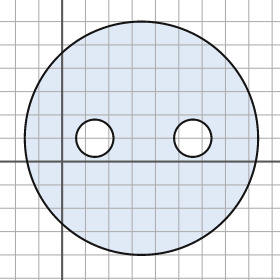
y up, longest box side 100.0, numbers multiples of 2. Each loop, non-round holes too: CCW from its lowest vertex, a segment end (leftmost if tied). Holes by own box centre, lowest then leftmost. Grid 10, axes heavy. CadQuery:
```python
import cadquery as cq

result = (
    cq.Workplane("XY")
    .moveTo(34.0, 10.0)
    .circle(50.0)
    .moveTo(14.0, 10.0)
    .circle(8.0)
    .moveTo(56.0, 10.0)
    .circle(8.0)
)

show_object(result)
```